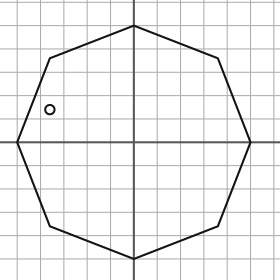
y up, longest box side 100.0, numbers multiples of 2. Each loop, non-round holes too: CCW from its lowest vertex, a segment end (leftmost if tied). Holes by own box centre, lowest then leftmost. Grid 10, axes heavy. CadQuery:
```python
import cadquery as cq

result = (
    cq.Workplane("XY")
    .moveTo(0.0, -50.0)
    .lineTo(36.0, -36.0)
    .lineTo(50.0, 0.0)
    .lineTo(36.0, 36.0)
    .lineTo(0.0, 50.0)
    .lineTo(-36.0, 36.0)
    .lineTo(-50.0, 0.0)
    .lineTo(-36.0, -36.0)
    .close()
    .moveTo(-36.0, 14.0)
    .circle(2.0)
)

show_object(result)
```